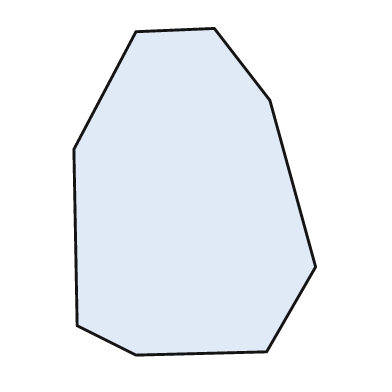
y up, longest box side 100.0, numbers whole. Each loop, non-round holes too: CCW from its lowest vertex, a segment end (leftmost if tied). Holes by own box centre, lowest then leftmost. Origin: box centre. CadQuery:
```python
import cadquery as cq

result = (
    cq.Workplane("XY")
    .moveTo(-18.0, -50.0)
    .lineTo(22.0, -49.0)
    .lineTo(37.0, -23.0)
    .lineTo(23.0, 28.0)
    .lineTo(6.0, 50.0)
    .lineTo(-18.0, 49.0)
    .lineTo(-37.0, 13.0)
    .lineTo(-36.0, -41.0)
    .close()
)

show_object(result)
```